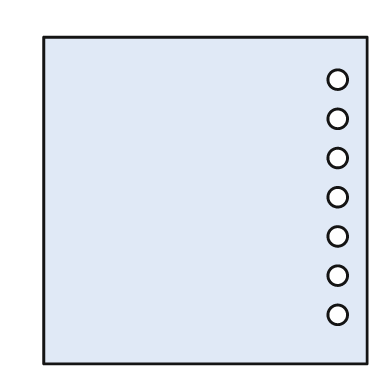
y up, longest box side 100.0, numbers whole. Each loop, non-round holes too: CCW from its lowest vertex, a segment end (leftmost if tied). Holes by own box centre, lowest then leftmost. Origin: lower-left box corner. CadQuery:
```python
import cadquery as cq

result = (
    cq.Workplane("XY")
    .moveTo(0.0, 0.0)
    .lineTo(99.0, 0.0)
    .lineTo(99.0, 100.0)
    .lineTo(0.0, 100.0)
    .close()
    .moveTo(90.0, 15.0)
    .circle(3.0)
    .moveTo(90.0, 27.0)
    .circle(3.0)
    .moveTo(90.0, 39.0)
    .circle(3.0)
    .moveTo(90.0, 51.0)
    .circle(3.0)
    .moveTo(90.0, 63.0)
    .circle(3.0)
    .moveTo(90.0, 75.0)
    .circle(3.0)
    .moveTo(90.0, 87.0)
    .circle(3.0)
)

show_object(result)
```